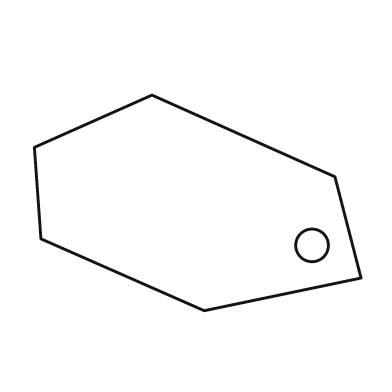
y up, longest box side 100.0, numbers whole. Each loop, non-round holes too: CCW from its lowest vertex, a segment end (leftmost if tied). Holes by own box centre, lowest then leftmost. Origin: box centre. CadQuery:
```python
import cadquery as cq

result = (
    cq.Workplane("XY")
    .moveTo(2.0, -33.0)
    .lineTo(50.0, -23.0)
    .lineTo(42.0, 8.0)
    .lineTo(-14.0, 33.0)
    .lineTo(-50.0, 17.0)
    .lineTo(-48.0, -11.0)
    .close()
    .moveTo(35.0, -13.0)
    .circle(5.0)
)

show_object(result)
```